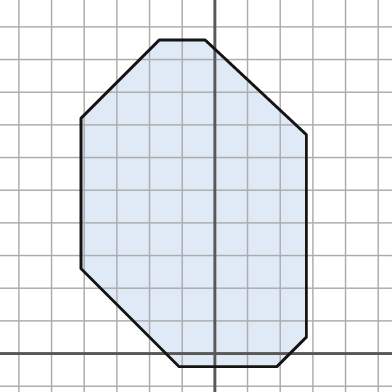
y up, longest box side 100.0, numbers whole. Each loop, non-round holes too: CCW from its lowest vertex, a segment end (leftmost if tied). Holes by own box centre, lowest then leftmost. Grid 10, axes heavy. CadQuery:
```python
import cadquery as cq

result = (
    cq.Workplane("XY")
    .moveTo(-11.0, -4.0)
    .lineTo(19.0, -4.0)
    .lineTo(28.0, 5.0)
    .lineTo(28.0, 67.0)
    .lineTo(-3.0, 96.0)
    .lineTo(-17.0, 96.0)
    .lineTo(-41.0, 72.0)
    .lineTo(-41.0, 26.0)
    .close()
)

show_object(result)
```